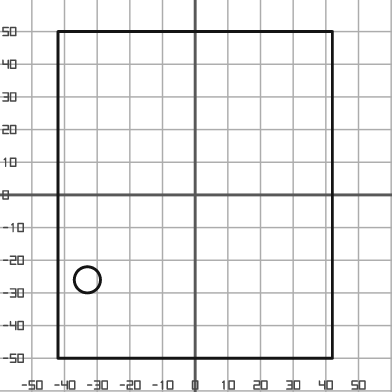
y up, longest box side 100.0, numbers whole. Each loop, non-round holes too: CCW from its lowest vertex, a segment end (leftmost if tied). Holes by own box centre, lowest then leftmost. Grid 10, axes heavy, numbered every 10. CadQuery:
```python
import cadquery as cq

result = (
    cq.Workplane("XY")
    .moveTo(-42.0, -50.0)
    .lineTo(42.0, -50.0)
    .lineTo(42.0, 50.0)
    .lineTo(-42.0, 50.0)
    .close()
    .moveTo(-33.0, -26.0)
    .circle(4.0)
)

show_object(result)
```